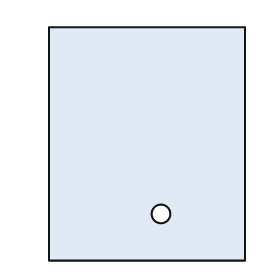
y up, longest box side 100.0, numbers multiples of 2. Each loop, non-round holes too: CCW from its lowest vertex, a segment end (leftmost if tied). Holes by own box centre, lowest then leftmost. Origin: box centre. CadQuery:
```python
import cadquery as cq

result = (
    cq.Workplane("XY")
    .moveTo(-42.0, -50.0)
    .lineTo(42.0, -50.0)
    .lineTo(42.0, 50.0)
    .lineTo(-42.0, 50.0)
    .close()
    .moveTo(6.0, -30.0)
    .circle(4.0)
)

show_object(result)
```